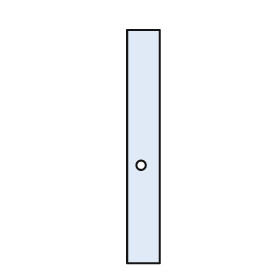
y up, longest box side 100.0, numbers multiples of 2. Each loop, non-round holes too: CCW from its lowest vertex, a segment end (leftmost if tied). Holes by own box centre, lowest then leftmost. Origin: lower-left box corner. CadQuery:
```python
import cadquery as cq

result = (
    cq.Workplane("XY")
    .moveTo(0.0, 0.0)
    .lineTo(14.0, 0.0)
    .lineTo(14.0, 100.0)
    .lineTo(0.0, 100.0)
    .close()
    .moveTo(6.0, 42.0)
    .circle(2.0)
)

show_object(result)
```